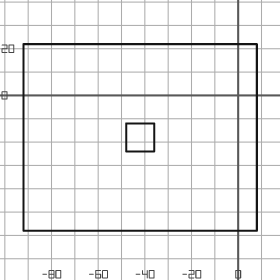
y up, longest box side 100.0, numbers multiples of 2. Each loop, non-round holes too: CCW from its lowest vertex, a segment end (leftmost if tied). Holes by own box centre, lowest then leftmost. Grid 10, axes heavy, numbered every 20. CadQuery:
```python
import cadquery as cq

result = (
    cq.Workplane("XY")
    .moveTo(-92.0, -58.0)
    .lineTo(8.0, -58.0)
    .lineTo(8.0, 22.0)
    .lineTo(-92.0, 22.0)
    .close()
    .moveTo(-48.0, -24.0)
    .lineTo(-36.0, -24.0)
    .lineTo(-36.0, -12.0)
    .lineTo(-48.0, -12.0)
    .close()
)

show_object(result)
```